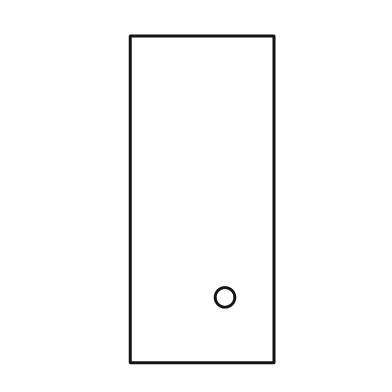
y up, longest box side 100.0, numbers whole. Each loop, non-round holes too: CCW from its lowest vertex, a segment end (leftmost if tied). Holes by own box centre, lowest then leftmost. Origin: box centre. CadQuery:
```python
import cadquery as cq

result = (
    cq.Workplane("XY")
    .moveTo(-22.0, -50.0)
    .lineTo(22.0, -50.0)
    .lineTo(22.0, 50.0)
    .lineTo(-22.0, 50.0)
    .close()
    .moveTo(7.0, -30.0)
    .circle(3.0)
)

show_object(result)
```